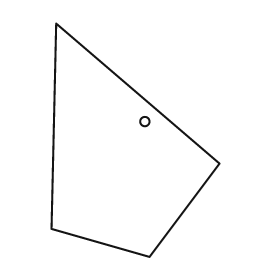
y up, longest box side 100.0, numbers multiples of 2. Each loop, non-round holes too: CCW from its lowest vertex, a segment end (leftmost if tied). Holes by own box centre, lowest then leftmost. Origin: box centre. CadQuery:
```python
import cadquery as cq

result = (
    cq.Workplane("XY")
    .moveTo(6.0, -50.0)
    .lineTo(36.0, -10.0)
    .lineTo(-34.0, 50.0)
    .lineTo(-36.0, -38.0)
    .close()
    .moveTo(4.0, 8.0)
    .circle(2.0)
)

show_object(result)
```